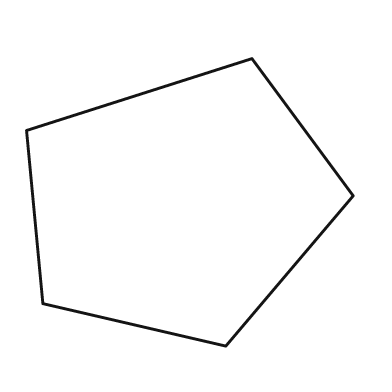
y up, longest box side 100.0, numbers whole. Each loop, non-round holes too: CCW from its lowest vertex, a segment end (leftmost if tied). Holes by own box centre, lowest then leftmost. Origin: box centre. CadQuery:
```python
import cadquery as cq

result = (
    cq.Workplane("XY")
    .moveTo(11.0, -44.0)
    .lineTo(50.0, 2.0)
    .lineTo(19.0, 44.0)
    .lineTo(-50.0, 22.0)
    .lineTo(-45.0, -31.0)
    .close()
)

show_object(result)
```